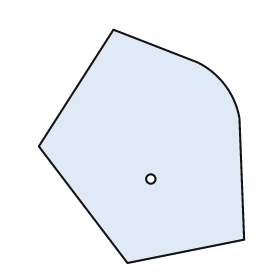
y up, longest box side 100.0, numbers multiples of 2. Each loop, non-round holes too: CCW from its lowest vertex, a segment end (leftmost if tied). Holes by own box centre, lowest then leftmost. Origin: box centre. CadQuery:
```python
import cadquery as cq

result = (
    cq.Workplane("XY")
    .moveTo(-6.0, -50.0)
    .lineTo(44.0, -40.0)
    .lineTo(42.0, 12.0)
    .threePointArc((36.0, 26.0), (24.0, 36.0))
    .lineTo(-12.0, 50.0)
    .lineTo(-44.0, 0.0)
    .close()
    .moveTo(4.0, -14.0)
    .circle(2.0)
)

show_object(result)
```